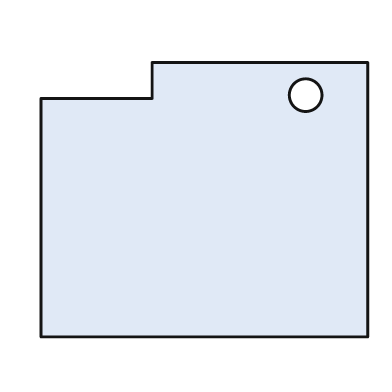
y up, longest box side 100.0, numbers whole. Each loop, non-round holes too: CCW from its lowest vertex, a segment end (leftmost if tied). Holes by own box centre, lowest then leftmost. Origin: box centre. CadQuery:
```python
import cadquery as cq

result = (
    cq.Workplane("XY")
    .moveTo(-50.0, -42.0)
    .lineTo(50.0, -42.0)
    .lineTo(50.0, 42.0)
    .lineTo(-16.0, 42.0)
    .lineTo(-16.0, 31.0)
    .lineTo(-50.0, 31.0)
    .close()
    .moveTo(31.0, 32.0)
    .circle(5.0)
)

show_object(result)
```